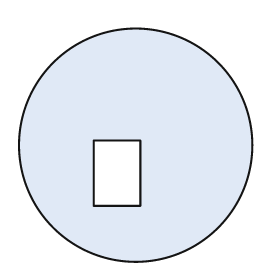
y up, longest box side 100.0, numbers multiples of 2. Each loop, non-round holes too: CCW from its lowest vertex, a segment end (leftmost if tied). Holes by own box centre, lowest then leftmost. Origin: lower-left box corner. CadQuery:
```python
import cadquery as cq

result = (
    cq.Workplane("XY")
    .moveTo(50.0, 50.0)
    .circle(50.0)
    .moveTo(32.0, 24.0)
    .lineTo(52.0, 24.0)
    .lineTo(52.0, 52.0)
    .lineTo(32.0, 52.0)
    .close()
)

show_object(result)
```